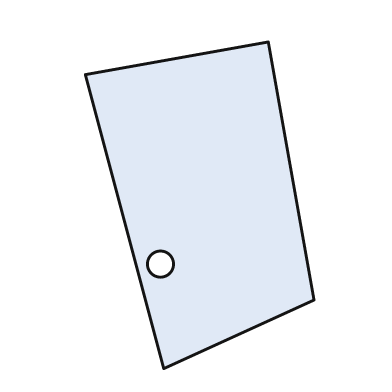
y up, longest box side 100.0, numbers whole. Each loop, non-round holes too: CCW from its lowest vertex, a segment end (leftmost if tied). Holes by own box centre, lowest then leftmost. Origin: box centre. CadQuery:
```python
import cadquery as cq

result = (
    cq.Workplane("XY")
    .moveTo(-11.0, -50.0)
    .lineTo(35.0, -29.0)
    .lineTo(21.0, 50.0)
    .lineTo(-35.0, 40.0)
    .close()
    .moveTo(-12.0, -18.0)
    .circle(4.0)
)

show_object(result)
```